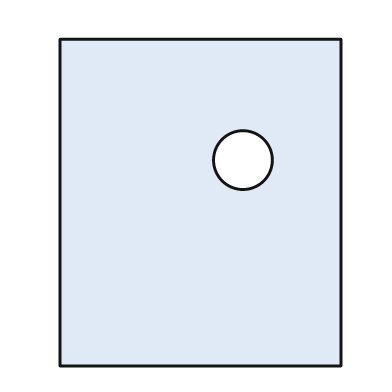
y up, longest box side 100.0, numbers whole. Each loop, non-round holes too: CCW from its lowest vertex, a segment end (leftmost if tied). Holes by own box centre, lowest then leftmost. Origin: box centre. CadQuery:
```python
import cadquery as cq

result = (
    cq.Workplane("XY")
    .moveTo(-43.0, -50.0)
    .lineTo(43.0, -50.0)
    .lineTo(43.0, 50.0)
    .lineTo(-43.0, 50.0)
    .close()
    .moveTo(13.0, 13.0)
    .circle(9.0)
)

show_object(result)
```